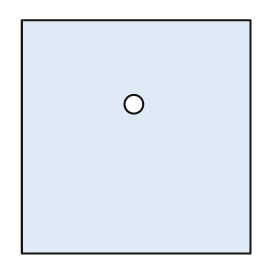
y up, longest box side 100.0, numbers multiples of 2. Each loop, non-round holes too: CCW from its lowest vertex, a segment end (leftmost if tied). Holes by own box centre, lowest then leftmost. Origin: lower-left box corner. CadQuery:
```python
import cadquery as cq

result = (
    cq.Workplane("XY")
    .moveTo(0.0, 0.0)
    .lineTo(98.0, 0.0)
    .lineTo(98.0, 100.0)
    .lineTo(0.0, 100.0)
    .close()
    .moveTo(48.0, 64.0)
    .circle(4.0)
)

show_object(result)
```